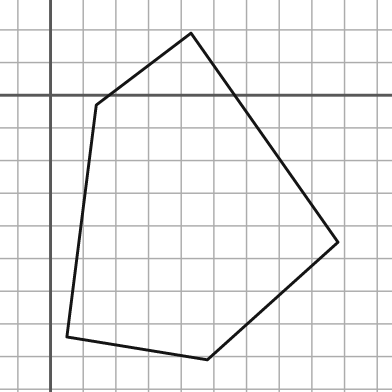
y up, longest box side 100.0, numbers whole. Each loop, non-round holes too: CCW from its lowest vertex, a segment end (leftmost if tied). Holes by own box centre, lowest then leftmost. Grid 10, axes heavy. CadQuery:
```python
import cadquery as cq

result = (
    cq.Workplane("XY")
    .moveTo(48.0, -81.0)
    .lineTo(88.0, -45.0)
    .lineTo(43.0, 19.0)
    .lineTo(14.0, -3.0)
    .lineTo(5.0, -74.0)
    .close()
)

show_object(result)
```